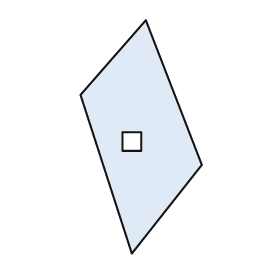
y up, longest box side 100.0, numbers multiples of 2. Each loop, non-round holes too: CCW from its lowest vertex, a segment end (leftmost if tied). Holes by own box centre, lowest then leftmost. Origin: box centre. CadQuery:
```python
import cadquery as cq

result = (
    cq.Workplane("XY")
    .moveTo(-4.0, -50.0)
    .lineTo(26.0, -12.0)
    .lineTo(2.0, 50.0)
    .lineTo(-26.0, 18.0)
    .close()
    .moveTo(-8.0, -6.0)
    .lineTo(0.0, -6.0)
    .lineTo(0.0, 2.0)
    .lineTo(-8.0, 2.0)
    .close()
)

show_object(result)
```